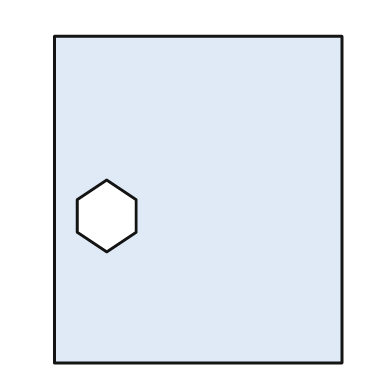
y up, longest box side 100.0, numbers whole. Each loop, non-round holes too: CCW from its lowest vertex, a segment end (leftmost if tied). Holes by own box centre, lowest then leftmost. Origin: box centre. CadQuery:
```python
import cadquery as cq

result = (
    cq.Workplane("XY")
    .moveTo(-44.0, -50.0)
    .lineTo(44.0, -50.0)
    .lineTo(44.0, 50.0)
    .lineTo(-44.0, 50.0)
    .close()
    .moveTo(-28.0, -16.0)
    .lineTo(-19.0, -10.0)
    .lineTo(-19.0, 0.0)
    .lineTo(-28.0, 6.0)
    .lineTo(-37.0, 0.0)
    .lineTo(-37.0, -10.0)
    .close()
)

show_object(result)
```